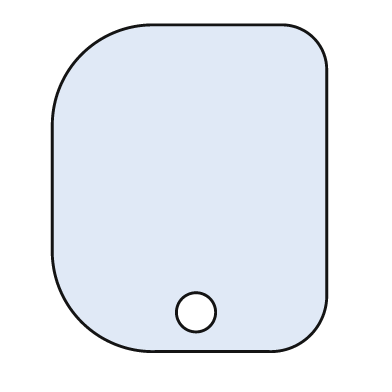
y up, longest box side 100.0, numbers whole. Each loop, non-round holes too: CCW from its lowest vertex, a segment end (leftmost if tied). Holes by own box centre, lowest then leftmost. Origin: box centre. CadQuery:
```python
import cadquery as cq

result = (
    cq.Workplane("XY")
    .moveTo(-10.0, -50.0)
    .lineTo(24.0, -50.0)
    .threePointArc((37.0, -45.0), (42.0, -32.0))
    .lineTo(42.0, 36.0)
    .threePointArc((38.0, 46.0), (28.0, 50.0))
    .lineTo(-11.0, 50.0)
    .threePointArc((-33.0, 41.0), (-42.0, 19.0))
    .lineTo(-42.0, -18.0)
    .threePointArc((-33.0, -41.0), (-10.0, -50.0))
    .close()
    .moveTo(2.0, -38.0)
    .circle(6.0)
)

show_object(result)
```